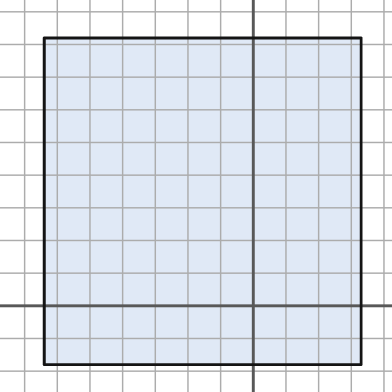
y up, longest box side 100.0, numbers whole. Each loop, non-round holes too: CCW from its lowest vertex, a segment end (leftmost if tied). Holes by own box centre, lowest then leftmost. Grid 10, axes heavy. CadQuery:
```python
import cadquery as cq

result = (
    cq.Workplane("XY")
    .moveTo(-64.0, -18.0)
    .lineTo(33.0, -18.0)
    .lineTo(33.0, 82.0)
    .lineTo(-64.0, 82.0)
    .close()
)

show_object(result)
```